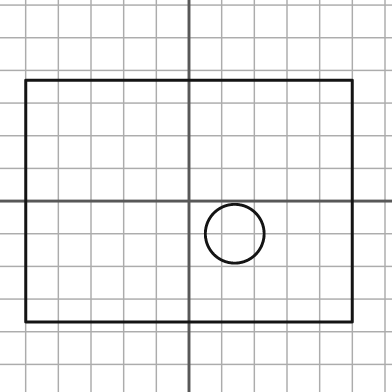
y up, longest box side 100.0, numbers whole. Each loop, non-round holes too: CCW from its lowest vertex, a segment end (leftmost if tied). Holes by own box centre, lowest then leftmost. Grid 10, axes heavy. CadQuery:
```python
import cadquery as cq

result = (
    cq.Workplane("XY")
    .moveTo(-50.0, -37.0)
    .lineTo(50.0, -37.0)
    .lineTo(50.0, 37.0)
    .lineTo(-50.0, 37.0)
    .close()
    .moveTo(14.0, -10.0)
    .circle(9.0)
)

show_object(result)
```